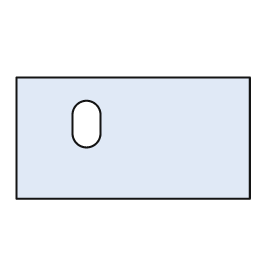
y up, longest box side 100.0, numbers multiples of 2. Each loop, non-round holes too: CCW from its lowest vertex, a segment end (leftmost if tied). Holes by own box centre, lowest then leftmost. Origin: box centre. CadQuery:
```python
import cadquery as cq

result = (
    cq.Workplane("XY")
    .moveTo(-50.0, -26.0)
    .lineTo(50.0, -26.0)
    .lineTo(50.0, 26.0)
    .lineTo(-50.0, 26.0)
    .close()
    .moveTo(-26.0, 2.0)
    .threePointArc((-20.0, -4.0), (-14.0, 2.0))
    .lineTo(-14.0, 10.0)
    .threePointArc((-20.0, 16.0), (-26.0, 10.0))
    .close()
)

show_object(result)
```